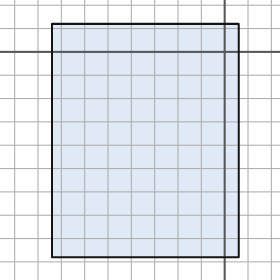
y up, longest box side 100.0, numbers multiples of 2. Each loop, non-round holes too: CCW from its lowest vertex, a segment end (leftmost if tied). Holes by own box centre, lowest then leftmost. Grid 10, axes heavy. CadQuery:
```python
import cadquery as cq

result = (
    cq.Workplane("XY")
    .moveTo(-74.0, -88.0)
    .lineTo(6.0, -88.0)
    .lineTo(6.0, 12.0)
    .lineTo(-74.0, 12.0)
    .close()
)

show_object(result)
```